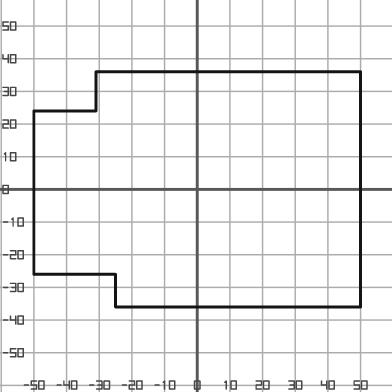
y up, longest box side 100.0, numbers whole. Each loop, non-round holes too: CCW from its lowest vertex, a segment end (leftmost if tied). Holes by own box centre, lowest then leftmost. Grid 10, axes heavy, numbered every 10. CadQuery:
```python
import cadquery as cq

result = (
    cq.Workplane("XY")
    .moveTo(-25.0, -36.0)
    .lineTo(50.0, -36.0)
    .lineTo(50.0, 36.0)
    .lineTo(-31.0, 36.0)
    .lineTo(-31.0, 24.0)
    .lineTo(-50.0, 24.0)
    .lineTo(-50.0, -26.0)
    .lineTo(-25.0, -26.0)
    .close()
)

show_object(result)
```